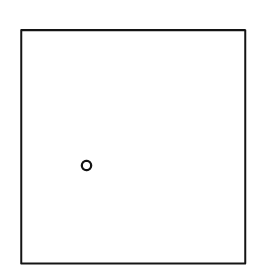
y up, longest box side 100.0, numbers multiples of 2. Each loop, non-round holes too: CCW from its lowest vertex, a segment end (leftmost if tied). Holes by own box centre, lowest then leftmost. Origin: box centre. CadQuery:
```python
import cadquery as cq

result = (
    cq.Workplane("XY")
    .moveTo(-48.0, -50.0)
    .lineTo(48.0, -50.0)
    .lineTo(48.0, 50.0)
    .lineTo(-48.0, 50.0)
    .close()
    .moveTo(-20.0, -8.0)
    .circle(2.0)
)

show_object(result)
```